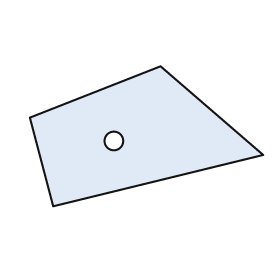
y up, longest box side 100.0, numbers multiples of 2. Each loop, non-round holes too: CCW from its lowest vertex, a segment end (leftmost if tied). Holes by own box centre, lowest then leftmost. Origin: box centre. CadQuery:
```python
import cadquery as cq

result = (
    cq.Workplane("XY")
    .moveTo(-40.0, -30.0)
    .lineTo(50.0, -8.0)
    .lineTo(6.0, 30.0)
    .lineTo(-50.0, 8.0)
    .close()
    .moveTo(-14.0, -2.0)
    .circle(4.0)
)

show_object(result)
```